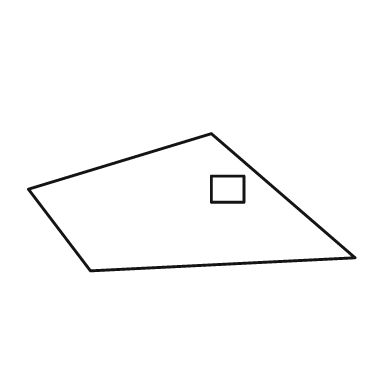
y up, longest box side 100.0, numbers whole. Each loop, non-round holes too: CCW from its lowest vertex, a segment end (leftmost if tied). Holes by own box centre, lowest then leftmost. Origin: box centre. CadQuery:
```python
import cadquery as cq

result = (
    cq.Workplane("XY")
    .moveTo(-31.0, -21.0)
    .lineTo(50.0, -17.0)
    .lineTo(6.0, 21.0)
    .lineTo(-50.0, 4.0)
    .close()
    .moveTo(6.0, 0.0)
    .lineTo(16.0, 0.0)
    .lineTo(16.0, 8.0)
    .lineTo(6.0, 8.0)
    .close()
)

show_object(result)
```